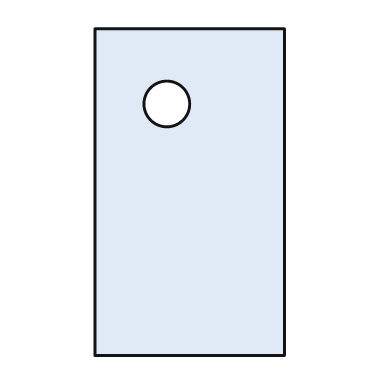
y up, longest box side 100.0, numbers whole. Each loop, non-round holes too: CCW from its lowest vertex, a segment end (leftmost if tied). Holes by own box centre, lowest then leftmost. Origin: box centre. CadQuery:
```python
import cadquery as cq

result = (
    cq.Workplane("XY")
    .moveTo(-29.0, -50.0)
    .lineTo(29.0, -50.0)
    .lineTo(29.0, 50.0)
    .lineTo(-29.0, 50.0)
    .close()
    .moveTo(-7.0, 27.0)
    .circle(7.0)
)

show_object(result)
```